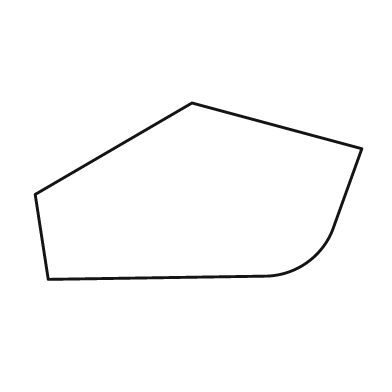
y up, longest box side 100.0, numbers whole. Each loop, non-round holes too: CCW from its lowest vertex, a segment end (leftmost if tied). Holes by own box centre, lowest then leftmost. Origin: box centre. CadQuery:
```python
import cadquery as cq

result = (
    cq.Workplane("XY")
    .moveTo(-46.0, -27.0)
    .lineTo(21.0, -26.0)
    .threePointArc((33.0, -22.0), (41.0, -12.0))
    .lineTo(50.0, 13.0)
    .lineTo(-2.0, 27.0)
    .lineTo(-50.0, -1.0)
    .close()
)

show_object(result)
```